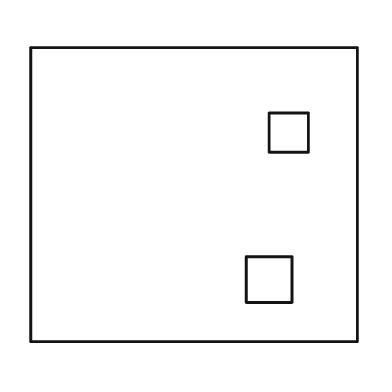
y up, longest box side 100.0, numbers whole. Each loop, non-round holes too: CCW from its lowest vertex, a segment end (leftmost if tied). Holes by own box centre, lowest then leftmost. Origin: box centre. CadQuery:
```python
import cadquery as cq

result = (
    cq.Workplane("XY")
    .moveTo(-50.0, -45.0)
    .lineTo(50.0, -45.0)
    .lineTo(50.0, 45.0)
    .lineTo(-50.0, 45.0)
    .close()
    .moveTo(16.0, -33.0)
    .lineTo(30.0, -33.0)
    .lineTo(30.0, -19.0)
    .lineTo(16.0, -19.0)
    .close()
    .moveTo(23.0, 13.0)
    .lineTo(35.0, 13.0)
    .lineTo(35.0, 25.0)
    .lineTo(23.0, 25.0)
    .close()
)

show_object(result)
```